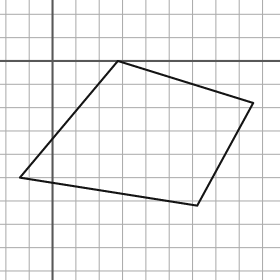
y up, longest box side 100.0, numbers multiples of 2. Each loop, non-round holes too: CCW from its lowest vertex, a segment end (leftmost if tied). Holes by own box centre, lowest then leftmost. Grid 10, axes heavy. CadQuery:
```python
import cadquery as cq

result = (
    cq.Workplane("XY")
    .moveTo(62.0, -62.0)
    .lineTo(86.0, -18.0)
    .lineTo(28.0, 0.0)
    .lineTo(-14.0, -50.0)
    .close()
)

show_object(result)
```